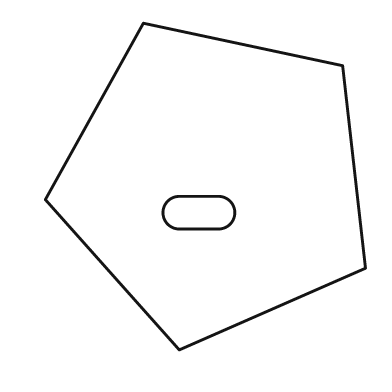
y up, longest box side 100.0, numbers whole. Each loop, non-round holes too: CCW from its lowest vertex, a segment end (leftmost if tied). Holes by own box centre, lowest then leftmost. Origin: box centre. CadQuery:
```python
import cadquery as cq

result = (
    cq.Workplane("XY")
    .moveTo(-8.0, -50.0)
    .lineTo(49.0, -25.0)
    .lineTo(42.0, 37.0)
    .lineTo(-19.0, 50.0)
    .lineTo(-49.0, -4.0)
    .close()
    .moveTo(-8.0, -13.0)
    .lineTo(4.0, -13.0)
    .threePointArc((9.0, -8.0), (4.0, -3.0))
    .lineTo(-8.0, -3.0)
    .threePointArc((-13.0, -8.0), (-8.0, -13.0))
    .close()
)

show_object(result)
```